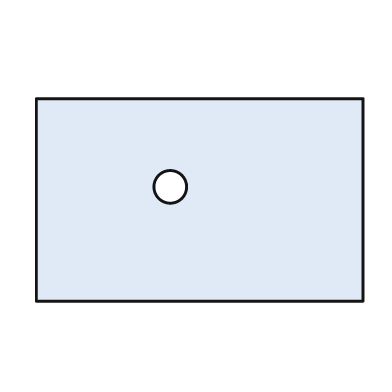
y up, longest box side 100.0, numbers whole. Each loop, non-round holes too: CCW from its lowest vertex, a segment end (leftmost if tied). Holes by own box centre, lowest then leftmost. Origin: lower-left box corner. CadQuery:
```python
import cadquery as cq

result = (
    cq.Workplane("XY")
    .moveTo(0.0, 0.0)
    .lineTo(100.0, 0.0)
    .lineTo(100.0, 62.0)
    .lineTo(0.0, 62.0)
    .close()
    .moveTo(41.0, 35.0)
    .circle(5.0)
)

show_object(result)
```